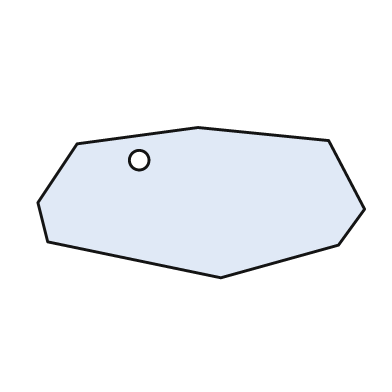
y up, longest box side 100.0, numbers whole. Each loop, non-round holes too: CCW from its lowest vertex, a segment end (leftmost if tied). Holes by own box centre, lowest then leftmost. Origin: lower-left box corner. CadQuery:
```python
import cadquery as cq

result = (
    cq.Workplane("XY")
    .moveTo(56.0, 0.0)
    .lineTo(92.0, 10.0)
    .lineTo(100.0, 21.0)
    .lineTo(89.0, 42.0)
    .lineTo(49.0, 46.0)
    .lineTo(12.0, 41.0)
    .lineTo(0.0, 23.0)
    .lineTo(3.0, 11.0)
    .close()
    .moveTo(31.0, 36.0)
    .circle(3.0)
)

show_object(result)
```